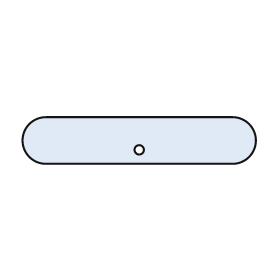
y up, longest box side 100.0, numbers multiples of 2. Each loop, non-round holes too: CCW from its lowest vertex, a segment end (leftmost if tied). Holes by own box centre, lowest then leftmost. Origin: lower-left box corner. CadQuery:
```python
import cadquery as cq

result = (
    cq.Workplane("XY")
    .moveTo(10.0, 0.0)
    .lineTo(90.0, 0.0)
    .threePointArc((100.0, 10.0), (90.0, 20.0))
    .lineTo(10.0, 20.0)
    .threePointArc((0.0, 10.0), (10.0, 0.0))
    .close()
    .moveTo(50.0, 6.0)
    .circle(2.0)
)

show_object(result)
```